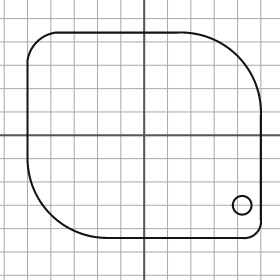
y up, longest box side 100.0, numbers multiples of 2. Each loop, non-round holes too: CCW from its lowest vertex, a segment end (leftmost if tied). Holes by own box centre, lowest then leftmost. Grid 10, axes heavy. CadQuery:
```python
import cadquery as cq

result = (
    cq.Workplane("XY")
    .moveTo(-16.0, -44.0)
    .lineTo(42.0, -44.0)
    .threePointArc((48.0, -42.0), (50.0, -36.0))
    .lineTo(50.0, 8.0)
    .threePointArc((40.0, 34.0), (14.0, 44.0))
    .lineTo(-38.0, 44.0)
    .threePointArc((-46.0, 40.0), (-50.0, 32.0))
    .lineTo(-50.0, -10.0)
    .threePointArc((-40.0, -34.0), (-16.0, -44.0))
    .close()
    .moveTo(42.0, -30.0)
    .circle(4.0)
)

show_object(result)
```